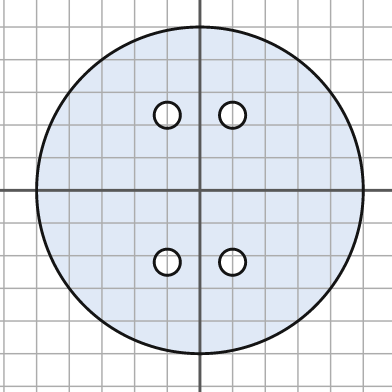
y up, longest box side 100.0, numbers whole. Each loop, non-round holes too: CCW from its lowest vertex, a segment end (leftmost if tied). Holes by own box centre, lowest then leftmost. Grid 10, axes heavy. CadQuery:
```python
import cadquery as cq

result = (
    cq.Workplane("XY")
    .moveTo(0.0, 0.0)
    .circle(50.0)
    .moveTo(-10.0, -22.0)
    .circle(4.0)
    .moveTo(10.0, -22.0)
    .circle(4.0)
    .moveTo(-10.0, 23.0)
    .circle(4.0)
    .moveTo(10.0, 23.0)
    .circle(4.0)
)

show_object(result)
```